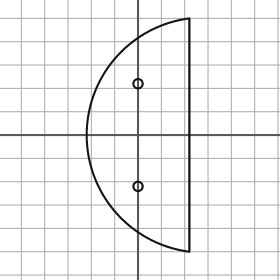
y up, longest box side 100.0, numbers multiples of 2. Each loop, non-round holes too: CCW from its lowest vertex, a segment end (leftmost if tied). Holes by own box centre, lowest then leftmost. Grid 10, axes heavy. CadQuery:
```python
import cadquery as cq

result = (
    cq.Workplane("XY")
    .moveTo(22.0, -50.0)
    .lineTo(22.0, 50.0)
    .threePointArc((-22.0, 0.0), (22.0, -50.0))
    .close()
    .moveTo(0.0, -22.0)
    .circle(2.0)
    .moveTo(0.0, 22.0)
    .circle(2.0)
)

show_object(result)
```